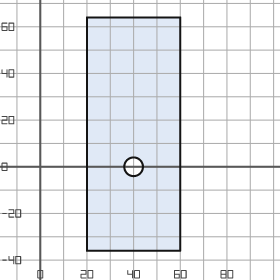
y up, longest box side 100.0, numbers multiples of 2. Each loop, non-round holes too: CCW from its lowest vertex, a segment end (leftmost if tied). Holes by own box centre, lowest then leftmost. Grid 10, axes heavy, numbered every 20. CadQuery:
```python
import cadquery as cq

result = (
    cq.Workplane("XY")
    .moveTo(20.0, -36.0)
    .lineTo(60.0, -36.0)
    .lineTo(60.0, 64.0)
    .lineTo(20.0, 64.0)
    .close()
    .moveTo(40.0, 0.0)
    .circle(4.0)
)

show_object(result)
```